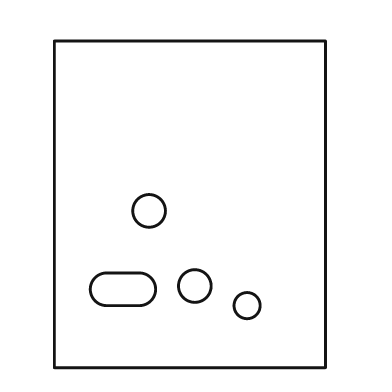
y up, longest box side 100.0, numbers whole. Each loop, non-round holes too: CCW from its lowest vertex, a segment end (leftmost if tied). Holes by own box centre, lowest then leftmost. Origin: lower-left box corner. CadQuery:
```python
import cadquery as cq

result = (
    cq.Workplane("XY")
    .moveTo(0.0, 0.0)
    .lineTo(83.0, 0.0)
    .lineTo(83.0, 100.0)
    .lineTo(0.0, 100.0)
    .close()
    .moveTo(59.0, 19.0)
    .circle(4.0)
    .moveTo(16.0, 19.0)
    .lineTo(26.0, 19.0)
    .threePointArc((31.0, 24.0), (26.0, 29.0))
    .lineTo(16.0, 29.0)
    .threePointArc((11.0, 24.0), (16.0, 19.0))
    .close()
    .moveTo(43.0, 25.0)
    .circle(5.0)
    .moveTo(29.0, 48.0)
    .circle(5.0)
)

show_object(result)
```